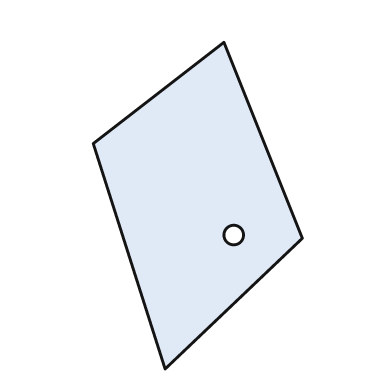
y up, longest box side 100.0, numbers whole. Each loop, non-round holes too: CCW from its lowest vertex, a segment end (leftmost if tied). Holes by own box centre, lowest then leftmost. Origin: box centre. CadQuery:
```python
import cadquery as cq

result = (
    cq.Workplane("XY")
    .moveTo(-10.0, -50.0)
    .lineTo(32.0, -10.0)
    .lineTo(8.0, 50.0)
    .lineTo(-32.0, 19.0)
    .close()
    .moveTo(11.0, -9.0)
    .circle(3.0)
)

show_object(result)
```